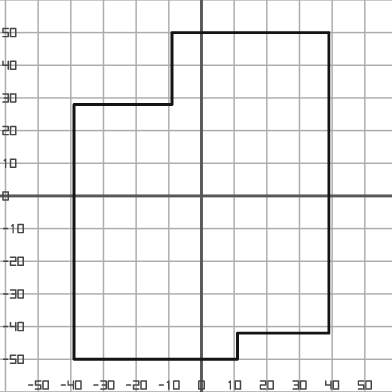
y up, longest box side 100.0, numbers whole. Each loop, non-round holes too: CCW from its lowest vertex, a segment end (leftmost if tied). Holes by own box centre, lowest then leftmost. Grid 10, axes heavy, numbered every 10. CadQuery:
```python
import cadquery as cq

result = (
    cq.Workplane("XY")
    .moveTo(-39.0, -50.0)
    .lineTo(11.0, -50.0)
    .lineTo(11.0, -42.0)
    .lineTo(39.0, -42.0)
    .lineTo(39.0, 50.0)
    .lineTo(-9.0, 50.0)
    .lineTo(-9.0, 28.0)
    .lineTo(-39.0, 28.0)
    .close()
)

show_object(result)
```